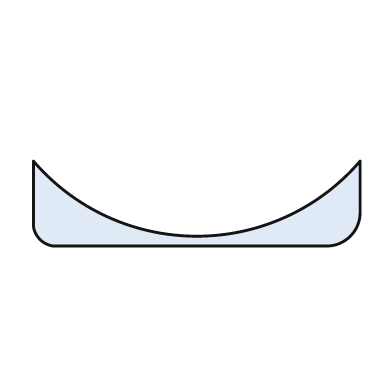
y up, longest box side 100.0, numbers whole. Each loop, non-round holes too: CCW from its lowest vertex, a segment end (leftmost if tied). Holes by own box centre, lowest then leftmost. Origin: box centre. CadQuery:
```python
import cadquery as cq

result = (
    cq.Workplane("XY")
    .moveTo(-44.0, -13.0)
    .lineTo(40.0, -13.0)
    .threePointArc((47.0, -10.0), (50.0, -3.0))
    .lineTo(50.0, 13.0)
    .threePointArc((0.0, -10.0), (-50.0, 13.0))
    .lineTo(-50.0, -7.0)
    .threePointArc((-48.0, -11.0), (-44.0, -13.0))
    .close()
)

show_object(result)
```